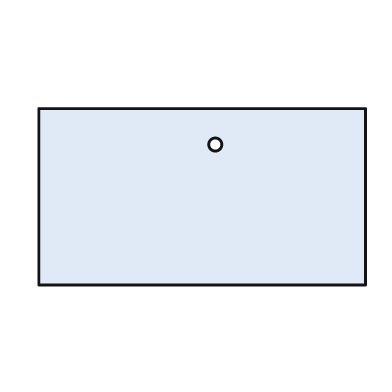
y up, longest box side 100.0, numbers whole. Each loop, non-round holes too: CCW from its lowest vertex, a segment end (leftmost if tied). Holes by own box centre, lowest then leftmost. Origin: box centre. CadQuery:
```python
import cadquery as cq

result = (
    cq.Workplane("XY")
    .moveTo(-50.0, -27.0)
    .lineTo(50.0, -27.0)
    .lineTo(50.0, 27.0)
    .lineTo(-50.0, 27.0)
    .close()
    .moveTo(4.0, 16.0)
    .circle(2.0)
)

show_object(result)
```